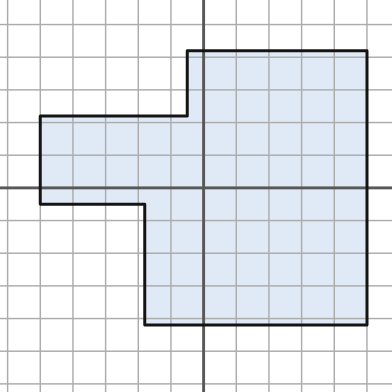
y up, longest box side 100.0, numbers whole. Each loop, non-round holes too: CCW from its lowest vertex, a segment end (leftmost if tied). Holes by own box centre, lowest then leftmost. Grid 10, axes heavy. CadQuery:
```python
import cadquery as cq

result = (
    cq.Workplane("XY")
    .moveTo(-18.0, -42.0)
    .lineTo(50.0, -42.0)
    .lineTo(50.0, 42.0)
    .lineTo(-5.0, 42.0)
    .lineTo(-5.0, 22.0)
    .lineTo(-50.0, 22.0)
    .lineTo(-50.0, -5.0)
    .lineTo(-18.0, -5.0)
    .close()
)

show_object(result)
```